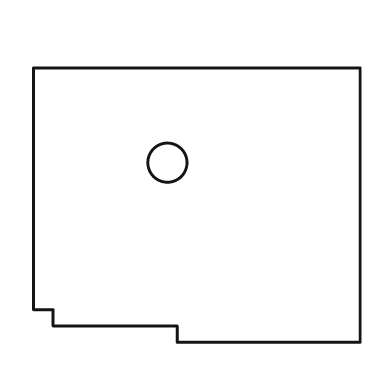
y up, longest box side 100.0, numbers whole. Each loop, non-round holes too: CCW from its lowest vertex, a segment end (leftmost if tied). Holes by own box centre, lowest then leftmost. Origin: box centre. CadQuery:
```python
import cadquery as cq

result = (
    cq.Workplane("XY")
    .moveTo(-6.0, -42.0)
    .lineTo(50.0, -42.0)
    .lineTo(50.0, 42.0)
    .lineTo(-50.0, 42.0)
    .lineTo(-50.0, -32.0)
    .lineTo(-44.0, -32.0)
    .lineTo(-44.0, -37.0)
    .lineTo(-6.0, -37.0)
    .close()
    .moveTo(-9.0, 13.0)
    .circle(6.0)
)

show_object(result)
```